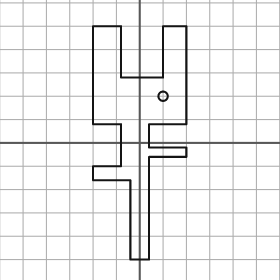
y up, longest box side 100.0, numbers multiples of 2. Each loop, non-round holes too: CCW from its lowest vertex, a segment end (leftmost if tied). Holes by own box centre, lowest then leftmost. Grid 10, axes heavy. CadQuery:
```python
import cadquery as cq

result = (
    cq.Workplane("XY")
    .moveTo(-4.0, -50.0)
    .lineTo(4.0, -50.0)
    .lineTo(4.0, -6.0)
    .lineTo(20.0, -6.0)
    .lineTo(20.0, -2.0)
    .lineTo(4.0, -2.0)
    .lineTo(4.0, 8.0)
    .lineTo(20.0, 8.0)
    .lineTo(20.0, 50.0)
    .lineTo(10.0, 50.0)
    .lineTo(10.0, 28.0)
    .lineTo(-8.0, 28.0)
    .lineTo(-8.0, 50.0)
    .lineTo(-20.0, 50.0)
    .lineTo(-20.0, 8.0)
    .lineTo(-8.0, 8.0)
    .lineTo(-8.0, -10.0)
    .lineTo(-20.0, -10.0)
    .lineTo(-20.0, -16.0)
    .lineTo(-4.0, -16.0)
    .close()
    .moveTo(10.0, 20.0)
    .circle(2.0)
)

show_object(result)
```